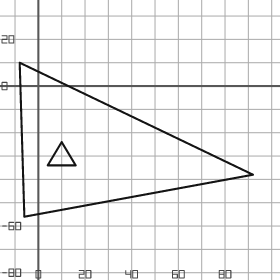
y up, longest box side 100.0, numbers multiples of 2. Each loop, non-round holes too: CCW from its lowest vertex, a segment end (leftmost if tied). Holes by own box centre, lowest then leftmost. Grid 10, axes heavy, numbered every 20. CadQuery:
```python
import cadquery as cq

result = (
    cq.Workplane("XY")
    .moveTo(-6.0, -56.0)
    .lineTo(92.0, -38.0)
    .lineTo(-8.0, 10.0)
    .close()
    .moveTo(4.0, -34.0)
    .lineTo(16.0, -34.0)
    .lineTo(10.0, -24.0)
    .close()
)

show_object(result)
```